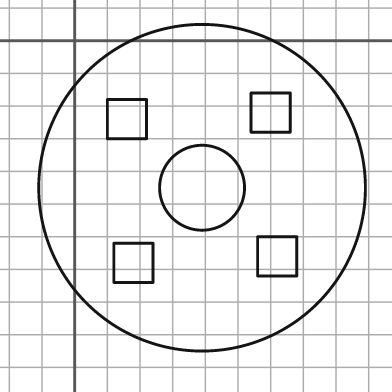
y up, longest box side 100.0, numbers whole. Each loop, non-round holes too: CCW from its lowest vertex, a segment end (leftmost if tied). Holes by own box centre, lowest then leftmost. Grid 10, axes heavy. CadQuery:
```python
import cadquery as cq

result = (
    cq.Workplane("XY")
    .moveTo(39.0, -45.0)
    .circle(50.0)
    .moveTo(12.0, -74.0)
    .lineTo(24.0, -74.0)
    .lineTo(24.0, -62.0)
    .lineTo(12.0, -62.0)
    .close()
    .moveTo(56.0, -72.0)
    .lineTo(68.0, -72.0)
    .lineTo(68.0, -60.0)
    .lineTo(56.0, -60.0)
    .close()
    .moveTo(39.0, -45.0)
    .circle(13.0)
    .moveTo(10.0, -30.0)
    .lineTo(22.0, -30.0)
    .lineTo(22.0, -18.0)
    .lineTo(10.0, -18.0)
    .close()
    .moveTo(54.0, -28.0)
    .lineTo(66.0, -28.0)
    .lineTo(66.0, -16.0)
    .lineTo(54.0, -16.0)
    .close()
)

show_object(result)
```